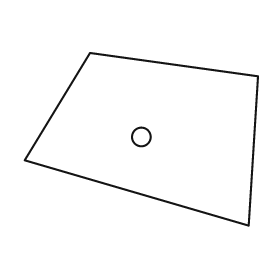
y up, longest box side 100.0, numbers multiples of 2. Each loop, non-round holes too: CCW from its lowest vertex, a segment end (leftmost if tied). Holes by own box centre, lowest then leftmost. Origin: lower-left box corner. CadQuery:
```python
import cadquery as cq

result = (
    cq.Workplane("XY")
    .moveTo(96.0, 0.0)
    .lineTo(100.0, 64.0)
    .lineTo(28.0, 74.0)
    .lineTo(0.0, 28.0)
    .close()
    .moveTo(50.0, 38.0)
    .circle(4.0)
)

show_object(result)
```